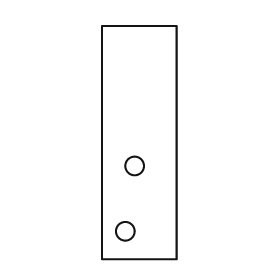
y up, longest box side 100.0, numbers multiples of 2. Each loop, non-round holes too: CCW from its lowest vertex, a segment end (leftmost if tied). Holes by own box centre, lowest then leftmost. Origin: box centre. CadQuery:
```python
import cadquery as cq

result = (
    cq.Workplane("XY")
    .moveTo(-16.0, -50.0)
    .lineTo(16.0, -50.0)
    .lineTo(16.0, 50.0)
    .lineTo(-16.0, 50.0)
    .close()
    .moveTo(-6.0, -38.0)
    .circle(4.0)
    .moveTo(-2.0, -10.0)
    .circle(4.0)
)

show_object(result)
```